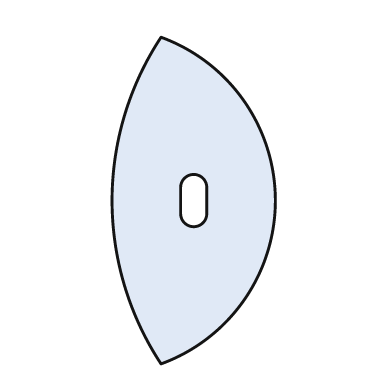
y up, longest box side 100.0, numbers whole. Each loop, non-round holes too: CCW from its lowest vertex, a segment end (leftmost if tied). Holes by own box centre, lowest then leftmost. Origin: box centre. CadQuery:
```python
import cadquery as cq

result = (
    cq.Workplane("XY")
    .moveTo(-10.0, -50.0)
    .threePointArc((25.0, 0.0), (-10.0, 50.0))
    .threePointArc((-25.0, 0.0), (-10.0, -50.0))
    .close()
    .moveTo(-4.0, -4.0)
    .threePointArc((0.0, -8.0), (4.0, -4.0))
    .lineTo(4.0, 4.0)
    .threePointArc((0.0, 8.0), (-4.0, 4.0))
    .close()
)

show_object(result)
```